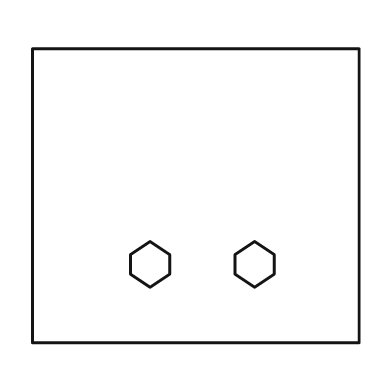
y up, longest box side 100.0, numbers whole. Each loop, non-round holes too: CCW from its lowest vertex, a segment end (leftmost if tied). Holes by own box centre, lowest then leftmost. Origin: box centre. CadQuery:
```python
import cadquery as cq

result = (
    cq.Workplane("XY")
    .moveTo(-50.0, -45.0)
    .lineTo(50.0, -45.0)
    .lineTo(50.0, 45.0)
    .lineTo(-50.0, 45.0)
    .close()
    .moveTo(-14.0, -28.0)
    .lineTo(-8.0, -24.0)
    .lineTo(-8.0, -18.0)
    .lineTo(-14.0, -14.0)
    .lineTo(-20.0, -18.0)
    .lineTo(-20.0, -24.0)
    .close()
    .moveTo(18.0, -28.0)
    .lineTo(24.0, -24.0)
    .lineTo(24.0, -18.0)
    .lineTo(18.0, -14.0)
    .lineTo(12.0, -18.0)
    .lineTo(12.0, -24.0)
    .close()
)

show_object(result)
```